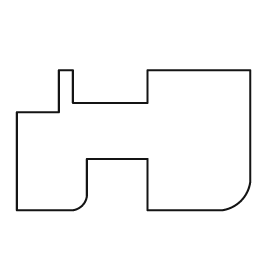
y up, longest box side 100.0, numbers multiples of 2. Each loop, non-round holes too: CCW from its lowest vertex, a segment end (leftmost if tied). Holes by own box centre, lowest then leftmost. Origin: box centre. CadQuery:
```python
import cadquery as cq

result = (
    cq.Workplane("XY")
    .moveTo(-50.0, -30.0)
    .lineTo(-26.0, -30.0)
    .threePointArc((-22.0, -28.0), (-20.0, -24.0))
    .lineTo(-20.0, -8.0)
    .lineTo(6.0, -8.0)
    .lineTo(6.0, -30.0)
    .lineTo(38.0, -30.0)
    .threePointArc((46.0, -26.0), (50.0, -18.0))
    .lineTo(50.0, 30.0)
    .lineTo(6.0, 30.0)
    .lineTo(6.0, 16.0)
    .lineTo(-26.0, 16.0)
    .lineTo(-26.0, 30.0)
    .lineTo(-32.0, 30.0)
    .lineTo(-32.0, 12.0)
    .lineTo(-50.0, 12.0)
    .close()
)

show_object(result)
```